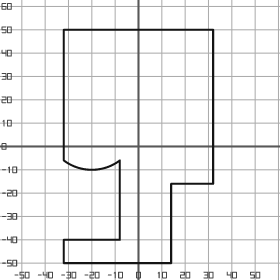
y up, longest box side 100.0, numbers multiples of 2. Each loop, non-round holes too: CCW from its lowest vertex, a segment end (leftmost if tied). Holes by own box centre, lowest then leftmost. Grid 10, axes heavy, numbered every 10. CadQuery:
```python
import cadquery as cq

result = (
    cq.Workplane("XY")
    .moveTo(-32.0, -50.0)
    .lineTo(14.0, -50.0)
    .lineTo(14.0, -16.0)
    .lineTo(32.0, -16.0)
    .lineTo(32.0, 50.0)
    .lineTo(-32.0, 50.0)
    .lineTo(-32.0, -6.0)
    .threePointArc((-20.0, -10.0), (-8.0, -6.0))
    .lineTo(-8.0, -40.0)
    .lineTo(-32.0, -40.0)
    .close()
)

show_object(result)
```